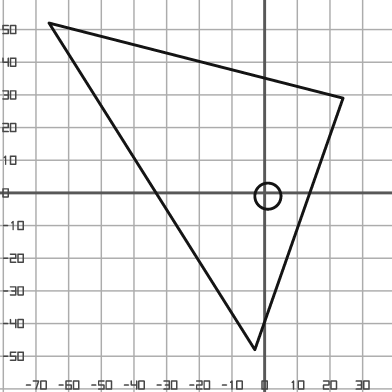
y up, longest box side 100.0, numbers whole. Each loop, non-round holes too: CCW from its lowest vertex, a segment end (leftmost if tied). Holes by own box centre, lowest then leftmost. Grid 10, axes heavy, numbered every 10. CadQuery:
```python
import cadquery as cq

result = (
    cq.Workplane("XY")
    .moveTo(-3.0, -48.0)
    .lineTo(24.0, 29.0)
    .lineTo(-66.0, 52.0)
    .close()
    .moveTo(1.0, -1.0)
    .circle(4.0)
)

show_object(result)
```